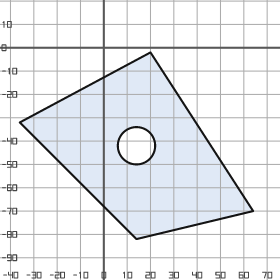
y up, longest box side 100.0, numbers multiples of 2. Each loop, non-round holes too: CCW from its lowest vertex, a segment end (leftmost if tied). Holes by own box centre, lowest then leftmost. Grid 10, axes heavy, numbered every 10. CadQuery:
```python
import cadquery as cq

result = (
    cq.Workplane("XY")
    .moveTo(14.0, -82.0)
    .lineTo(64.0, -70.0)
    .lineTo(20.0, -2.0)
    .lineTo(-36.0, -32.0)
    .close()
    .moveTo(14.0, -42.0)
    .circle(8.0)
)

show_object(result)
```